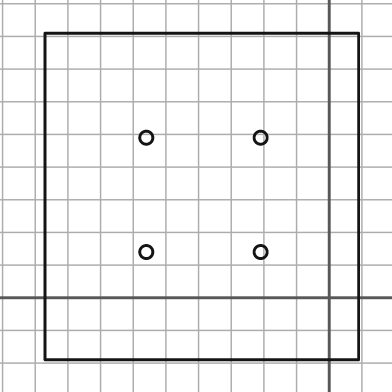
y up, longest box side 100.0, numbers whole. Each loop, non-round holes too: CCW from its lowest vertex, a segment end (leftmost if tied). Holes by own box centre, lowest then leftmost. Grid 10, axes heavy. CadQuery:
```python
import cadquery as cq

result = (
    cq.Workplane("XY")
    .moveTo(-87.0, -19.0)
    .lineTo(9.0, -19.0)
    .lineTo(9.0, 81.0)
    .lineTo(-87.0, 81.0)
    .close()
    .moveTo(-56.0, 14.0)
    .circle(2.0)
    .moveTo(-21.0, 14.0)
    .circle(2.0)
    .moveTo(-56.0, 49.0)
    .circle(2.0)
    .moveTo(-21.0, 49.0)
    .circle(2.0)
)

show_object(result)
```